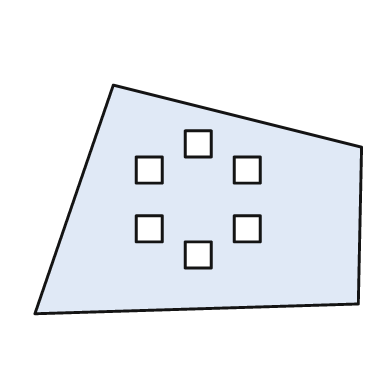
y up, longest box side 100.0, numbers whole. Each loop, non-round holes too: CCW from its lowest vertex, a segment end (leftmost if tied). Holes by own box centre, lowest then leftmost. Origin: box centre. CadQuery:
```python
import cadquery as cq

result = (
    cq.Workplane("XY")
    .moveTo(-50.0, -35.0)
    .lineTo(49.0, -32.0)
    .lineTo(50.0, 16.0)
    .lineTo(-26.0, 35.0)
    .close()
    .moveTo(-4.0, -21.0)
    .lineTo(4.0, -21.0)
    .lineTo(4.0, -13.0)
    .lineTo(-4.0, -13.0)
    .close()
    .moveTo(-19.0, -13.0)
    .lineTo(-11.0, -13.0)
    .lineTo(-11.0, -5.0)
    .lineTo(-19.0, -5.0)
    .close()
    .moveTo(11.0, -13.0)
    .lineTo(19.0, -13.0)
    .lineTo(19.0, -5.0)
    .lineTo(11.0, -5.0)
    .close()
    .moveTo(-19.0, 5.0)
    .lineTo(-11.0, 5.0)
    .lineTo(-11.0, 13.0)
    .lineTo(-19.0, 13.0)
    .close()
    .moveTo(11.0, 5.0)
    .lineTo(19.0, 5.0)
    .lineTo(19.0, 13.0)
    .lineTo(11.0, 13.0)
    .close()
    .moveTo(-4.0, 13.0)
    .lineTo(4.0, 13.0)
    .lineTo(4.0, 21.0)
    .lineTo(-4.0, 21.0)
    .close()
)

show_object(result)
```